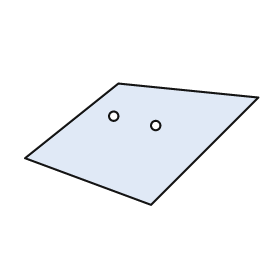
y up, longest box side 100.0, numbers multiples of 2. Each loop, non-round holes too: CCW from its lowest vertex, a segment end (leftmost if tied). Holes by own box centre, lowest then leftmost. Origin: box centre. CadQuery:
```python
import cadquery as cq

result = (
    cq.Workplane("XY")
    .moveTo(4.0, -26.0)
    .lineTo(50.0, 20.0)
    .lineTo(-10.0, 26.0)
    .lineTo(-50.0, -6.0)
    .close()
    .moveTo(6.0, 8.0)
    .circle(2.0)
    .moveTo(-12.0, 12.0)
    .circle(2.0)
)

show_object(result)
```